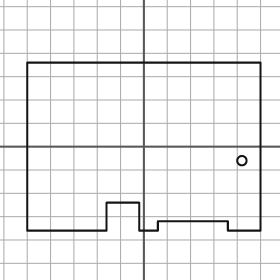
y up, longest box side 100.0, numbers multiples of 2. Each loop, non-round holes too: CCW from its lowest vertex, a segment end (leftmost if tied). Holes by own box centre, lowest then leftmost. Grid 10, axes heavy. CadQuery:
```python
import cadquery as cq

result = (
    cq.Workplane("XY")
    .moveTo(-50.0, -36.0)
    .lineTo(-16.0, -36.0)
    .lineTo(-16.0, -24.0)
    .lineTo(-2.0, -24.0)
    .lineTo(-2.0, -36.0)
    .lineTo(6.0, -36.0)
    .lineTo(6.0, -32.0)
    .lineTo(36.0, -32.0)
    .lineTo(36.0, -36.0)
    .lineTo(50.0, -36.0)
    .lineTo(50.0, 36.0)
    .lineTo(-50.0, 36.0)
    .close()
    .moveTo(42.0, -6.0)
    .circle(2.0)
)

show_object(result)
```